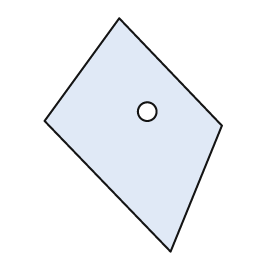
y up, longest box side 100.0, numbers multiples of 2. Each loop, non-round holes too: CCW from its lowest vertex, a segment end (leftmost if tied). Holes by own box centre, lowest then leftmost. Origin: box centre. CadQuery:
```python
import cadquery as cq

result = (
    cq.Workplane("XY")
    .moveTo(16.0, -50.0)
    .lineTo(38.0, 4.0)
    .lineTo(-6.0, 50.0)
    .lineTo(-38.0, 6.0)
    .close()
    .moveTo(6.0, 10.0)
    .circle(4.0)
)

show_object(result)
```